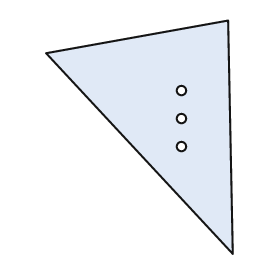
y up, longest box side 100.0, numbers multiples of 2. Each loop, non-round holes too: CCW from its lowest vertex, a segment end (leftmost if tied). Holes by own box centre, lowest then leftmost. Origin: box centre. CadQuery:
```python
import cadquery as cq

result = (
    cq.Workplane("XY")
    .moveTo(40.0, -50.0)
    .lineTo(38.0, 50.0)
    .lineTo(-40.0, 36.0)
    .close()
    .moveTo(18.0, -4.0)
    .circle(2.0)
    .moveTo(18.0, 8.0)
    .circle(2.0)
    .moveTo(18.0, 20.0)
    .circle(2.0)
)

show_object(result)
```